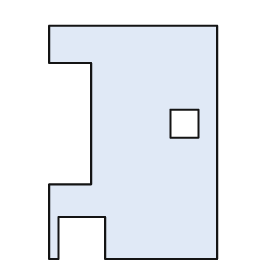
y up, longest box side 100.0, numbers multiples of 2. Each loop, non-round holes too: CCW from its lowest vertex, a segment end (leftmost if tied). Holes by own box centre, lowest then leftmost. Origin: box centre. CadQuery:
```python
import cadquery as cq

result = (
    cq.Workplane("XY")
    .moveTo(-36.0, -50.0)
    .lineTo(-32.0, -50.0)
    .lineTo(-32.0, -32.0)
    .lineTo(-12.0, -32.0)
    .lineTo(-12.0, -50.0)
    .lineTo(36.0, -50.0)
    .lineTo(36.0, 50.0)
    .lineTo(-36.0, 50.0)
    .lineTo(-36.0, 34.0)
    .lineTo(-18.0, 34.0)
    .lineTo(-18.0, -18.0)
    .lineTo(-36.0, -18.0)
    .close()
    .moveTo(16.0, 2.0)
    .lineTo(28.0, 2.0)
    .lineTo(28.0, 14.0)
    .lineTo(16.0, 14.0)
    .close()
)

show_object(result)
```